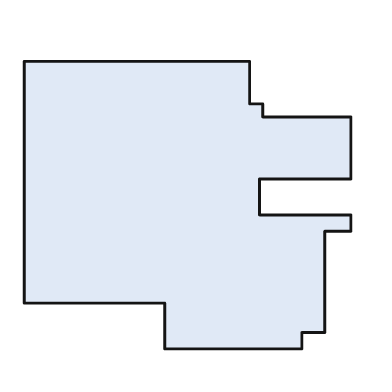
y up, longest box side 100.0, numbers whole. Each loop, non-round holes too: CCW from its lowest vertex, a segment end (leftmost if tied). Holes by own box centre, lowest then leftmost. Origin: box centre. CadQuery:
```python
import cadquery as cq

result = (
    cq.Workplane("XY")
    .moveTo(-7.0, -44.0)
    .lineTo(35.0, -44.0)
    .lineTo(35.0, -39.0)
    .lineTo(42.0, -39.0)
    .lineTo(42.0, -8.0)
    .lineTo(50.0, -8.0)
    .lineTo(50.0, -3.0)
    .lineTo(22.0, -3.0)
    .lineTo(22.0, 8.0)
    .lineTo(50.0, 8.0)
    .lineTo(50.0, 27.0)
    .lineTo(23.0, 27.0)
    .lineTo(23.0, 31.0)
    .lineTo(19.0, 31.0)
    .lineTo(19.0, 44.0)
    .lineTo(-50.0, 44.0)
    .lineTo(-50.0, -30.0)
    .lineTo(-7.0, -30.0)
    .close()
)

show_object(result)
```